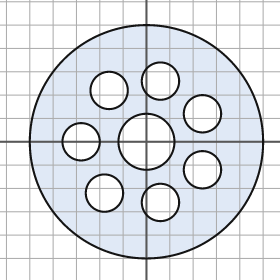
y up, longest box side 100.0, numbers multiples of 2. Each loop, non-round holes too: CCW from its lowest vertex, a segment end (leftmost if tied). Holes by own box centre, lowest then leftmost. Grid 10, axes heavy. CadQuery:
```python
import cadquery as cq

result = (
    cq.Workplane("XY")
    .moveTo(0.0, 0.0)
    .circle(50.0)
    .moveTo(6.0, -26.0)
    .circle(8.0)
    .moveTo(-18.0, -22.0)
    .circle(8.0)
    .moveTo(24.0, -12.0)
    .circle(8.0)
    .moveTo(-28.0, 0.0)
    .circle(8.0)
    .moveTo(0.0, 0.0)
    .circle(12.0)
    .moveTo(24.0, 12.0)
    .circle(8.0)
    .moveTo(-16.0, 22.0)
    .circle(8.0)
    .moveTo(6.0, 26.0)
    .circle(8.0)
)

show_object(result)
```